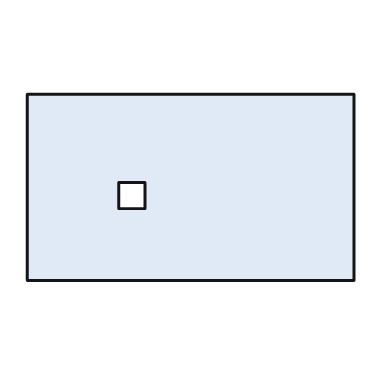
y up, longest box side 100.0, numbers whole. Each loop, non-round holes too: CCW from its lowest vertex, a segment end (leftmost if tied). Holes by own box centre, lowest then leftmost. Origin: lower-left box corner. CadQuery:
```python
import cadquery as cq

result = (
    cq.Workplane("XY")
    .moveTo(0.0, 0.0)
    .lineTo(100.0, 0.0)
    .lineTo(100.0, 57.0)
    .lineTo(0.0, 57.0)
    .close()
    .moveTo(28.0, 22.0)
    .lineTo(36.0, 22.0)
    .lineTo(36.0, 30.0)
    .lineTo(28.0, 30.0)
    .close()
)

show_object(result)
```